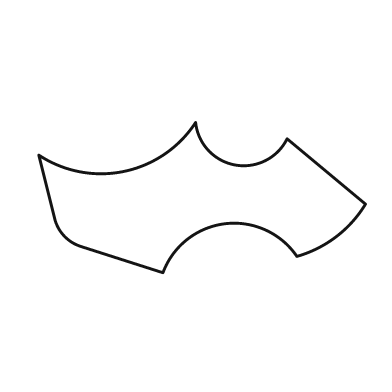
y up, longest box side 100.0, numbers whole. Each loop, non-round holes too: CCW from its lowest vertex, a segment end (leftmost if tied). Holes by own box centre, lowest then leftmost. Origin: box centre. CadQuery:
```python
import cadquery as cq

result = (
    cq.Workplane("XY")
    .moveTo(-12.0, -23.0)
    .threePointArc((7.0, -8.0), (29.0, -18.0))
    .threePointArc((41.0, -12.0), (50.0, -2.0))
    .lineTo(26.0, 18.0)
    .threePointArc((10.0, 10.0), (-2.0, 23.0))
    .threePointArc((-24.0, 8.0), (-50.0, 13.0))
    .lineTo(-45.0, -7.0)
    .threePointArc((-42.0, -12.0), (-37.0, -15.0))
    .close()
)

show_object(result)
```